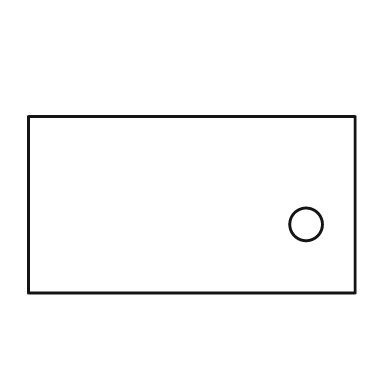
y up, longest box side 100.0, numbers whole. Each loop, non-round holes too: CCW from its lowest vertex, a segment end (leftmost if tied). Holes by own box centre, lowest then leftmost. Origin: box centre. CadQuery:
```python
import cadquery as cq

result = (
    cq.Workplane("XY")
    .moveTo(-50.0, -27.0)
    .lineTo(50.0, -27.0)
    .lineTo(50.0, 27.0)
    .lineTo(-50.0, 27.0)
    .close()
    .moveTo(35.0, -6.0)
    .circle(5.0)
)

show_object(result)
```